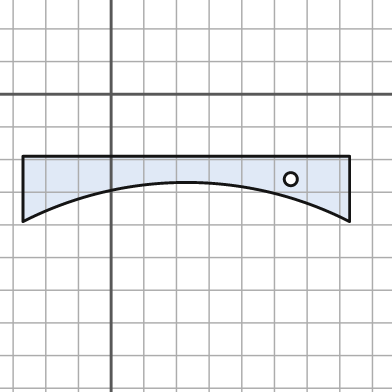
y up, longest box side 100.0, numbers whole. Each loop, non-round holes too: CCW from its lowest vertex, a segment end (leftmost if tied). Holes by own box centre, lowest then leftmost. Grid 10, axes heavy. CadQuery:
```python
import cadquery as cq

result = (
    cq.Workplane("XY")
    .moveTo(-27.0, -39.0)
    .threePointArc((23.0, -27.0), (73.0, -39.0))
    .lineTo(73.0, -19.0)
    .lineTo(-27.0, -19.0)
    .close()
    .moveTo(55.0, -26.0)
    .circle(2.0)
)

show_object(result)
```